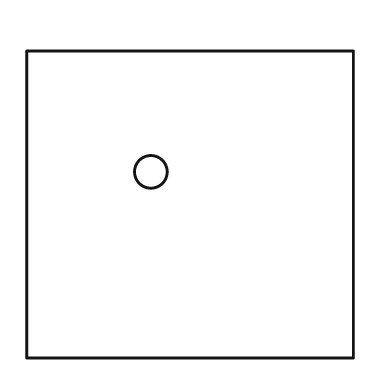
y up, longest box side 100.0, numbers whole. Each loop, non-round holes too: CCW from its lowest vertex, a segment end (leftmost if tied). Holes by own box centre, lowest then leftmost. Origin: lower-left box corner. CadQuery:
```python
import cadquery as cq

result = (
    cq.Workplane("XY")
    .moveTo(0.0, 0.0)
    .lineTo(100.0, 0.0)
    .lineTo(100.0, 94.0)
    .lineTo(0.0, 94.0)
    .close()
    .moveTo(38.0, 57.0)
    .circle(5.0)
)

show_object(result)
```